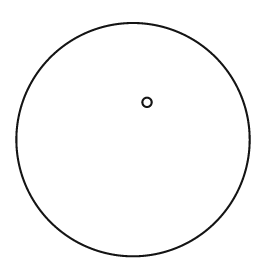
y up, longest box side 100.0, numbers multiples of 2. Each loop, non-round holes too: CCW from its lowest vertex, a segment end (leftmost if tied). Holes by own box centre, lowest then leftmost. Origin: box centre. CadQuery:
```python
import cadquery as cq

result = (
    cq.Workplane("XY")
    .moveTo(0.0, 0.0)
    .circle(50.0)
    .moveTo(6.0, 16.0)
    .circle(2.0)
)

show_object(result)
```